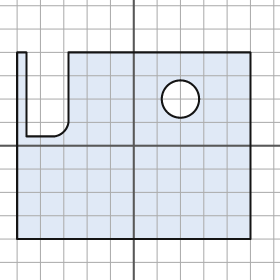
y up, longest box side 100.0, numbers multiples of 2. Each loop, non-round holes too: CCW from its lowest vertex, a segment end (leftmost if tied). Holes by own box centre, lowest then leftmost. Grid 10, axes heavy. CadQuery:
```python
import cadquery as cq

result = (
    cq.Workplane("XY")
    .moveTo(-50.0, -40.0)
    .lineTo(50.0, -40.0)
    .lineTo(50.0, 40.0)
    .lineTo(-28.0, 40.0)
    .lineTo(-28.0, 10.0)
    .threePointArc((-30.0, 6.0), (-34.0, 4.0))
    .lineTo(-46.0, 4.0)
    .lineTo(-46.0, 40.0)
    .lineTo(-50.0, 40.0)
    .close()
    .moveTo(20.0, 20.0)
    .circle(8.0)
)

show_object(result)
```